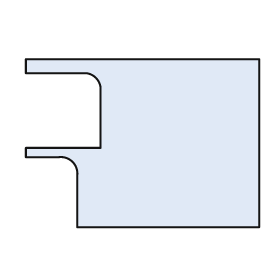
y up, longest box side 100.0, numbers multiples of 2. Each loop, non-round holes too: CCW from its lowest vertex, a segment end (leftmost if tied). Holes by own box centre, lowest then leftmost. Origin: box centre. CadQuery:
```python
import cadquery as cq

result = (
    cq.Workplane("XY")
    .moveTo(-28.0, -36.0)
    .lineTo(50.0, -36.0)
    .lineTo(50.0, 36.0)
    .lineTo(-50.0, 36.0)
    .lineTo(-50.0, 30.0)
    .lineTo(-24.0, 30.0)
    .threePointArc((-20.0, 28.0), (-18.0, 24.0))
    .lineTo(-18.0, -2.0)
    .lineTo(-50.0, -2.0)
    .lineTo(-50.0, -6.0)
    .lineTo(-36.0, -6.0)
    .threePointArc((-30.0, -8.0), (-28.0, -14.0))
    .close()
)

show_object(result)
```